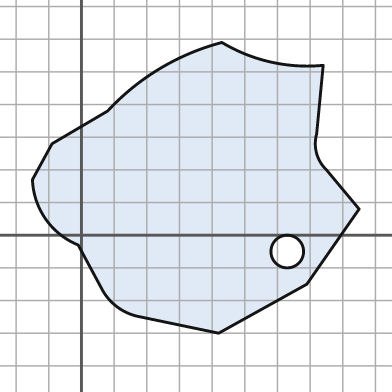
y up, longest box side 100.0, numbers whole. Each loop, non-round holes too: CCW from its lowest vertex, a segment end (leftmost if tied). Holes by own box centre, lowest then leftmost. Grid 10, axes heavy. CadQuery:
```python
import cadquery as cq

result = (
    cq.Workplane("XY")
    .moveTo(42.0, -30.0)
    .lineTo(69.0, -15.0)
    .lineTo(85.0, 8.0)
    .lineTo(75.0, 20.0)
    .threePointArc((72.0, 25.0), (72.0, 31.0))
    .lineTo(74.0, 52.0)
    .threePointArc((58.0, 53.0), (43.0, 59.0))
    .threePointArc((24.0, 51.0), (8.0, 38.0))
    .lineTo(-9.0, 28.0)
    .lineTo(-15.0, 17.0)
    .threePointArc((-11.0, 5.0), (-1.0, -3.0))
    .lineTo(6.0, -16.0)
    .threePointArc((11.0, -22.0), (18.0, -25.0))
    .close()
    .moveTo(63.0, -5.0)
    .circle(5.0)
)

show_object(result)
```